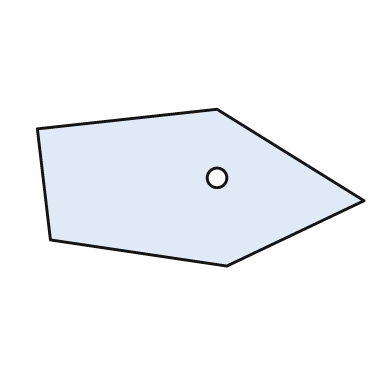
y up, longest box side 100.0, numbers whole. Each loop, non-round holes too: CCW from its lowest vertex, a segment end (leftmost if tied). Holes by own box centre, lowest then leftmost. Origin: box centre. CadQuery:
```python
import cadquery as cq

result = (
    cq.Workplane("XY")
    .moveTo(8.0, -24.0)
    .lineTo(50.0, -4.0)
    .lineTo(5.0, 24.0)
    .lineTo(-50.0, 18.0)
    .lineTo(-46.0, -16.0)
    .close()
    .moveTo(5.0, 3.0)
    .circle(3.0)
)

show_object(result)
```